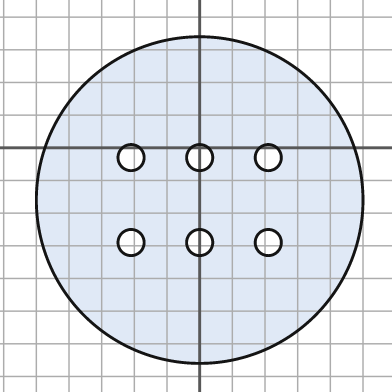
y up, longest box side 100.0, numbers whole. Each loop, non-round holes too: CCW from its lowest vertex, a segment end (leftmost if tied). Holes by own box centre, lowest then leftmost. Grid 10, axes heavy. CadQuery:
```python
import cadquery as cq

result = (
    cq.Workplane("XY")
    .moveTo(0.0, -16.0)
    .circle(50.0)
    .moveTo(-21.0, -29.0)
    .circle(4.0)
    .moveTo(0.0, -29.0)
    .circle(4.0)
    .moveTo(21.0, -29.0)
    .circle(4.0)
    .moveTo(-21.0, -3.0)
    .circle(4.0)
    .moveTo(0.0, -3.0)
    .circle(4.0)
    .moveTo(21.0, -3.0)
    .circle(4.0)
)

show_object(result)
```